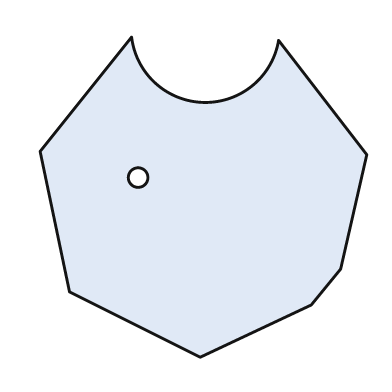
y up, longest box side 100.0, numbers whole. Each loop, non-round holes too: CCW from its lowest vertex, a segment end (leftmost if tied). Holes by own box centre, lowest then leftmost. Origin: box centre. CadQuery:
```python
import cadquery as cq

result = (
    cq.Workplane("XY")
    .moveTo(-1.0, -49.0)
    .lineTo(33.0, -33.0)
    .lineTo(42.0, -22.0)
    .lineTo(50.0, 13.0)
    .lineTo(23.0, 48.0)
    .threePointArc((0.0, 29.0), (-22.0, 49.0))
    .lineTo(-50.0, 14.0)
    .lineTo(-41.0, -29.0)
    .close()
    .moveTo(-20.0, 6.0)
    .circle(3.0)
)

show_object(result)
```